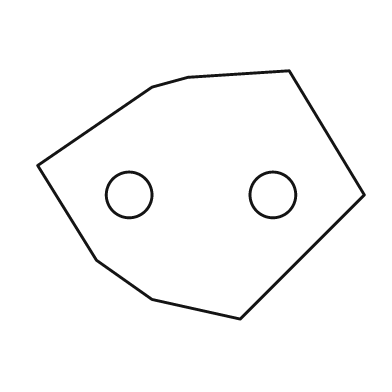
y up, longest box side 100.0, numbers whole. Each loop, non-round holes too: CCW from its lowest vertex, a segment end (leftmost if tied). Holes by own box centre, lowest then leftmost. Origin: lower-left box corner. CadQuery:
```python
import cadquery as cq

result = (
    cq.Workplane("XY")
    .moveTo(62.0, 0.0)
    .lineTo(100.0, 38.0)
    .lineTo(77.0, 76.0)
    .lineTo(46.0, 74.0)
    .lineTo(35.0, 71.0)
    .lineTo(0.0, 47.0)
    .lineTo(18.0, 18.0)
    .lineTo(35.0, 6.0)
    .close()
    .moveTo(28.0, 38.0)
    .circle(7.0)
    .moveTo(72.0, 38.0)
    .circle(7.0)
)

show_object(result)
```